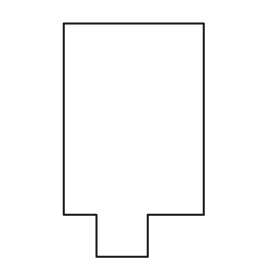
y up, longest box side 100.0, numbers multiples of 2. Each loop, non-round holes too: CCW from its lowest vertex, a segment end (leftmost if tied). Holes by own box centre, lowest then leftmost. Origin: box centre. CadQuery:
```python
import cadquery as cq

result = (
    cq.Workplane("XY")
    .moveTo(-16.0, -50.0)
    .lineTo(6.0, -50.0)
    .lineTo(6.0, -32.0)
    .lineTo(30.0, -32.0)
    .lineTo(30.0, 50.0)
    .lineTo(-30.0, 50.0)
    .lineTo(-30.0, -32.0)
    .lineTo(-16.0, -32.0)
    .close()
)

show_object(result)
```